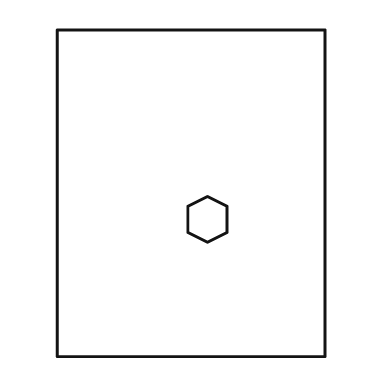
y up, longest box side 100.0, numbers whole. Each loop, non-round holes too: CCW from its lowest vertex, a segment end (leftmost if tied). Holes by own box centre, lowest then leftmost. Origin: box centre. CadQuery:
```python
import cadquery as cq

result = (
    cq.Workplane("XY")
    .moveTo(-41.0, -50.0)
    .lineTo(41.0, -50.0)
    .lineTo(41.0, 50.0)
    .lineTo(-41.0, 50.0)
    .close()
    .moveTo(5.0, -15.0)
    .lineTo(11.0, -12.0)
    .lineTo(11.0, -4.0)
    .lineTo(5.0, -1.0)
    .lineTo(-1.0, -4.0)
    .lineTo(-1.0, -12.0)
    .close()
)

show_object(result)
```